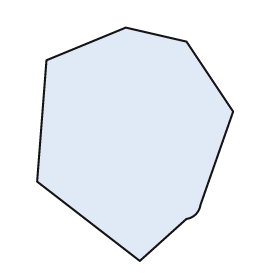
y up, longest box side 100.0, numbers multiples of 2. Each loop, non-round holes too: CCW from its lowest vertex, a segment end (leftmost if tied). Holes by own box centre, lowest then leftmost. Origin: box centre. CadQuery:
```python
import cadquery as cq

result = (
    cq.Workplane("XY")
    .moveTo(2.0, -50.0)
    .lineTo(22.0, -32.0)
    .threePointArc((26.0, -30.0), (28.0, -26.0))
    .lineTo(42.0, 14.0)
    .lineTo(22.0, 44.0)
    .lineTo(-4.0, 50.0)
    .lineTo(-38.0, 36.0)
    .lineTo(-42.0, -16.0)
    .close()
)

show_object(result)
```